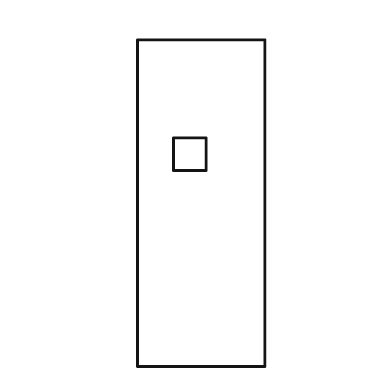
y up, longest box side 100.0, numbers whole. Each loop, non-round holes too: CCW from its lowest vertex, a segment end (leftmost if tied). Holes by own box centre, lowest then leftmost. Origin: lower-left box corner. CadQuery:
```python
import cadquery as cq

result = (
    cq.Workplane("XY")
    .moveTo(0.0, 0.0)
    .lineTo(39.0, 0.0)
    .lineTo(39.0, 100.0)
    .lineTo(0.0, 100.0)
    .close()
    .moveTo(11.0, 60.0)
    .lineTo(21.0, 60.0)
    .lineTo(21.0, 70.0)
    .lineTo(11.0, 70.0)
    .close()
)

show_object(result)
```